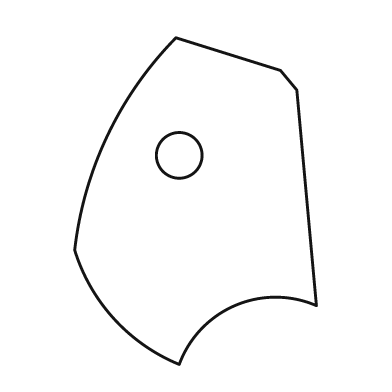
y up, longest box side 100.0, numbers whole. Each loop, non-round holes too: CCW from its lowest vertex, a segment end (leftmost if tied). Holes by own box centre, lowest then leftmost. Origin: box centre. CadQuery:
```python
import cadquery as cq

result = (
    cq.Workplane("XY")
    .moveTo(-5.0, -50.0)
    .threePointArc((12.0, -32.0), (37.0, -32.0))
    .lineTo(31.0, 34.0)
    .lineTo(26.0, 40.0)
    .lineTo(-6.0, 50.0)
    .threePointArc((-27.0, 20.0), (-37.0, -15.0))
    .threePointArc((-25.0, -36.0), (-5.0, -50.0))
    .close()
    .moveTo(-5.0, 14.0)
    .circle(7.0)
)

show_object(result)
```